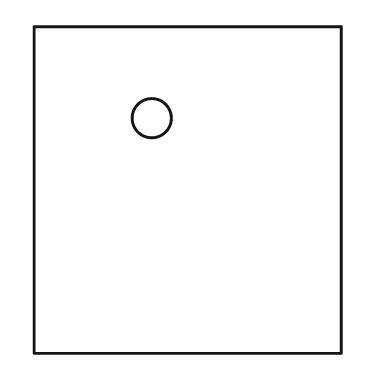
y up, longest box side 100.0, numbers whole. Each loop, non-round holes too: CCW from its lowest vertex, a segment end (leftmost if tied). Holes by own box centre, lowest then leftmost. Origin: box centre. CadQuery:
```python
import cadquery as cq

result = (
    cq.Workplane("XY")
    .moveTo(-47.0, -50.0)
    .lineTo(47.0, -50.0)
    .lineTo(47.0, 50.0)
    .lineTo(-47.0, 50.0)
    .close()
    .moveTo(-11.0, 22.0)
    .circle(6.0)
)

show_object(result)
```